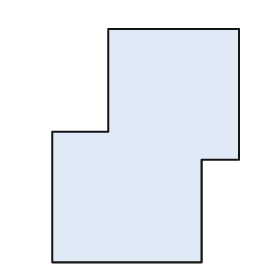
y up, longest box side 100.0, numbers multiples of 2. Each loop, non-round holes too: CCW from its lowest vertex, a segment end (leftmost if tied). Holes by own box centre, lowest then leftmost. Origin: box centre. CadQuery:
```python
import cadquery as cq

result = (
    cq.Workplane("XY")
    .moveTo(-40.0, -50.0)
    .lineTo(24.0, -50.0)
    .lineTo(24.0, -6.0)
    .lineTo(40.0, -6.0)
    .lineTo(40.0, 50.0)
    .lineTo(-16.0, 50.0)
    .lineTo(-16.0, 6.0)
    .lineTo(-40.0, 6.0)
    .close()
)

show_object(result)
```